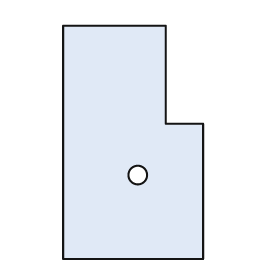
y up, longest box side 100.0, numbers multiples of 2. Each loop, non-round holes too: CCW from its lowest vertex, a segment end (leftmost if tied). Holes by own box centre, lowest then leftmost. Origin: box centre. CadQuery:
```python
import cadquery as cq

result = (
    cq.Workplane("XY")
    .moveTo(-30.0, -50.0)
    .lineTo(30.0, -50.0)
    .lineTo(30.0, 8.0)
    .lineTo(14.0, 8.0)
    .lineTo(14.0, 50.0)
    .lineTo(-30.0, 50.0)
    .close()
    .moveTo(2.0, -14.0)
    .circle(4.0)
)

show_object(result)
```